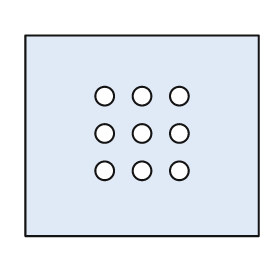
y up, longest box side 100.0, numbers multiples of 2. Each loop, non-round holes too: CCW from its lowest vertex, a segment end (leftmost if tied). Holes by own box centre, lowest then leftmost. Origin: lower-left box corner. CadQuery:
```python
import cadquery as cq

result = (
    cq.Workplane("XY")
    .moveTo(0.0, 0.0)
    .lineTo(100.0, 0.0)
    .lineTo(100.0, 86.0)
    .lineTo(0.0, 86.0)
    .close()
    .moveTo(34.0, 28.0)
    .circle(4.0)
    .moveTo(50.0, 28.0)
    .circle(4.0)
    .moveTo(66.0, 28.0)
    .circle(4.0)
    .moveTo(34.0, 44.0)
    .circle(4.0)
    .moveTo(50.0, 44.0)
    .circle(4.0)
    .moveTo(66.0, 44.0)
    .circle(4.0)
    .moveTo(34.0, 60.0)
    .circle(4.0)
    .moveTo(50.0, 60.0)
    .circle(4.0)
    .moveTo(66.0, 60.0)
    .circle(4.0)
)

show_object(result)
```